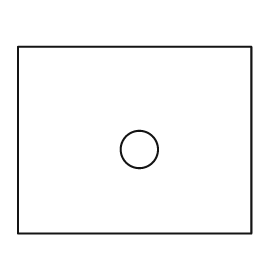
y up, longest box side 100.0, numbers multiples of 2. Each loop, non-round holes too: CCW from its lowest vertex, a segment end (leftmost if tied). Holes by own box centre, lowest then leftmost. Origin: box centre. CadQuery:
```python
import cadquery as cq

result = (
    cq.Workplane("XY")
    .moveTo(-50.0, -40.0)
    .lineTo(50.0, -40.0)
    .lineTo(50.0, 40.0)
    .lineTo(-50.0, 40.0)
    .close()
    .moveTo(2.0, -4.0)
    .circle(8.0)
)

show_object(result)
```